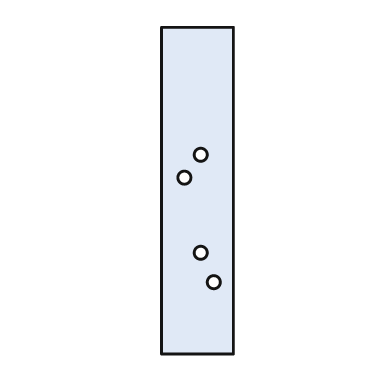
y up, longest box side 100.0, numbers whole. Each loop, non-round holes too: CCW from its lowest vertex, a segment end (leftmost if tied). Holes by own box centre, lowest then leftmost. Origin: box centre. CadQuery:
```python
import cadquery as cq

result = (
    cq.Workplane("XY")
    .moveTo(-11.0, -50.0)
    .lineTo(11.0, -50.0)
    .lineTo(11.0, 50.0)
    .lineTo(-11.0, 50.0)
    .close()
    .moveTo(5.0, -28.0)
    .circle(2.0)
    .moveTo(1.0, -19.0)
    .circle(2.0)
    .moveTo(-4.0, 4.0)
    .circle(2.0)
    .moveTo(1.0, 11.0)
    .circle(2.0)
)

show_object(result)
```